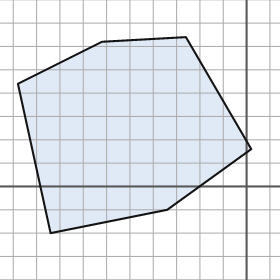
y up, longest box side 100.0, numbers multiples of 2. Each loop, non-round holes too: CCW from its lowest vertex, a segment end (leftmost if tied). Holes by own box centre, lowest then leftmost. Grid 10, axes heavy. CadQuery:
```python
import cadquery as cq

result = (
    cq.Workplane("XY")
    .moveTo(-84.0, -20.0)
    .lineTo(-34.0, -10.0)
    .lineTo(2.0, 16.0)
    .lineTo(-26.0, 64.0)
    .lineTo(-62.0, 62.0)
    .lineTo(-98.0, 44.0)
    .close()
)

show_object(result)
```